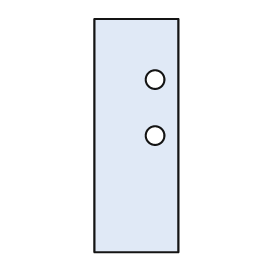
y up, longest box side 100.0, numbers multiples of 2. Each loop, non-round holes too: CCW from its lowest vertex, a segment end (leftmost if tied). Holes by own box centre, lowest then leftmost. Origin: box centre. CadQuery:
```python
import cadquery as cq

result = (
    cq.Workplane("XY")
    .moveTo(-18.0, -50.0)
    .lineTo(18.0, -50.0)
    .lineTo(18.0, 50.0)
    .lineTo(-18.0, 50.0)
    .close()
    .moveTo(8.0, 0.0)
    .circle(4.0)
    .moveTo(8.0, 24.0)
    .circle(4.0)
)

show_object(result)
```